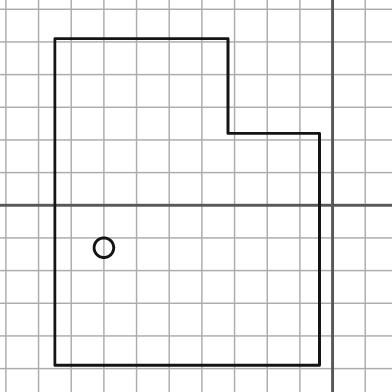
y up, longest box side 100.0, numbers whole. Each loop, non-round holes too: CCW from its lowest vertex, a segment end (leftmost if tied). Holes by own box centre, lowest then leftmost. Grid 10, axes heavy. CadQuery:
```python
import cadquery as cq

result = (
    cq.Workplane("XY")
    .moveTo(-85.0, -49.0)
    .lineTo(-4.0, -49.0)
    .lineTo(-4.0, 22.0)
    .lineTo(-32.0, 22.0)
    .lineTo(-32.0, 51.0)
    .lineTo(-85.0, 51.0)
    .close()
    .moveTo(-70.0, -13.0)
    .circle(3.0)
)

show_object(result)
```